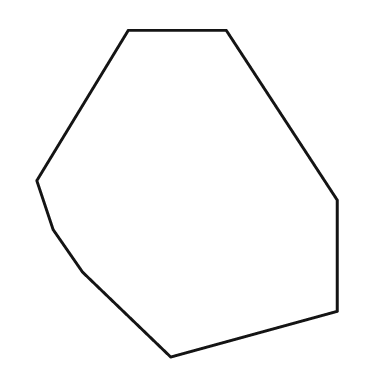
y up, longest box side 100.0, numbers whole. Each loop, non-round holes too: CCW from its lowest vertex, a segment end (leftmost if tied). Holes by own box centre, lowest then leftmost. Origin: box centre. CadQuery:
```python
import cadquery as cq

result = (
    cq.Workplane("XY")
    .moveTo(-5.0, -50.0)
    .lineTo(46.0, -36.0)
    .lineTo(46.0, -2.0)
    .lineTo(12.0, 50.0)
    .lineTo(-18.0, 50.0)
    .lineTo(-46.0, 4.0)
    .lineTo(-41.0, -11.0)
    .lineTo(-32.0, -24.0)
    .close()
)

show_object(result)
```